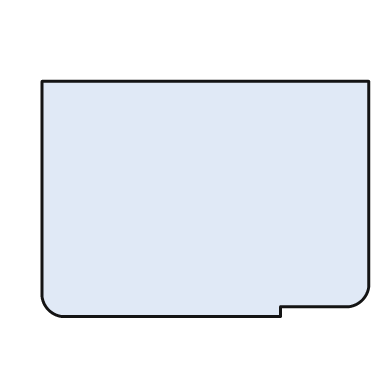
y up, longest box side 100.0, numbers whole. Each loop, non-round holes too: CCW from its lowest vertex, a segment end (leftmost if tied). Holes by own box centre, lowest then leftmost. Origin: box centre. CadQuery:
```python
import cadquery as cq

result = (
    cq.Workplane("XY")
    .moveTo(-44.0, -36.0)
    .lineTo(23.0, -36.0)
    .lineTo(23.0, -33.0)
    .lineTo(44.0, -33.0)
    .threePointArc((48.0, -31.0), (50.0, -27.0))
    .lineTo(50.0, 36.0)
    .lineTo(-50.0, 36.0)
    .lineTo(-50.0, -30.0)
    .threePointArc((-48.0, -34.0), (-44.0, -36.0))
    .close()
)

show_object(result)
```